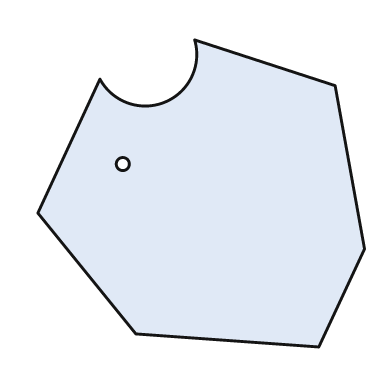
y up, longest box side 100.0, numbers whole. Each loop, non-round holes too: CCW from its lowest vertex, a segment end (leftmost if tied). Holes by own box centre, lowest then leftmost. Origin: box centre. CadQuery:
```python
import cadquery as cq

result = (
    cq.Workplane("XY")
    .moveTo(36.0, -47.0)
    .lineTo(50.0, -17.0)
    .lineTo(41.0, 33.0)
    .lineTo(-2.0, 47.0)
    .threePointArc((-11.0, 28.0), (-31.0, 35.0))
    .lineTo(-50.0, -6.0)
    .lineTo(-20.0, -43.0)
    .close()
    .moveTo(-24.0, 9.0)
    .circle(2.0)
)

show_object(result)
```